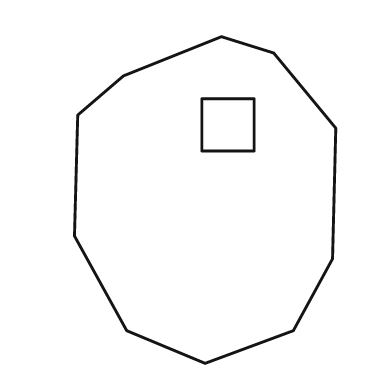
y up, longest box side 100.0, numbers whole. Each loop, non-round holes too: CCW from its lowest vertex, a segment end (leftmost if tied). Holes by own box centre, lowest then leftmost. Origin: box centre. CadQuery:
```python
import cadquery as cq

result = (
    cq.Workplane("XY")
    .moveTo(0.0, -50.0)
    .lineTo(27.0, -40.0)
    .lineTo(39.0, -18.0)
    .lineTo(40.0, 22.0)
    .lineTo(21.0, 45.0)
    .lineTo(5.0, 50.0)
    .lineTo(-25.0, 38.0)
    .lineTo(-39.0, 26.0)
    .lineTo(-40.0, -11.0)
    .lineTo(-24.0, -40.0)
    .close()
    .moveTo(-1.0, 15.0)
    .lineTo(15.0, 15.0)
    .lineTo(15.0, 31.0)
    .lineTo(-1.0, 31.0)
    .close()
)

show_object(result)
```